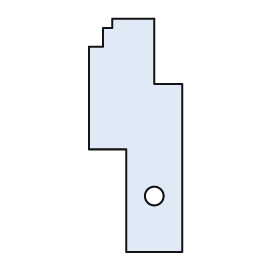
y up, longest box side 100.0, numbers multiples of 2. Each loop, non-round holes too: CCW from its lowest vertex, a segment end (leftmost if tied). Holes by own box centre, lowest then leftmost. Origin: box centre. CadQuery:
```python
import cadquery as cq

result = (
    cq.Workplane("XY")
    .moveTo(-4.0, -50.0)
    .lineTo(20.0, -50.0)
    .lineTo(20.0, 22.0)
    .lineTo(8.0, 22.0)
    .lineTo(8.0, 50.0)
    .lineTo(-10.0, 50.0)
    .lineTo(-10.0, 46.0)
    .lineTo(-14.0, 46.0)
    .lineTo(-14.0, 38.0)
    .lineTo(-20.0, 38.0)
    .lineTo(-20.0, -6.0)
    .lineTo(-4.0, -6.0)
    .close()
    .moveTo(8.0, -26.0)
    .circle(4.0)
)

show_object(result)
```